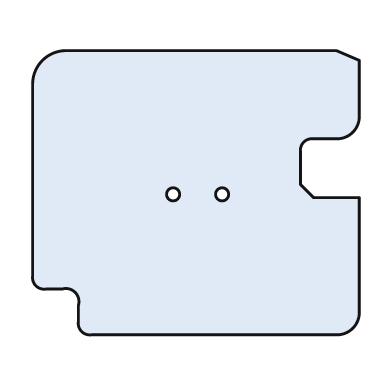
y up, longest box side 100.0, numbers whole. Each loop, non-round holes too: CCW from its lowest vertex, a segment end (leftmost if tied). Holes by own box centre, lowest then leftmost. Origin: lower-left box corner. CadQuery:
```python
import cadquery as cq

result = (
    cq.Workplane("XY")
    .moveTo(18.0, 0.0)
    .lineTo(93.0, 0.0)
    .threePointArc((98.0, 2.0), (100.0, 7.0))
    .lineTo(100.0, 42.0)
    .lineTo(86.0, 42.0)
    .lineTo(82.0, 46.0)
    .lineTo(82.0, 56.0)
    .threePointArc((83.0, 59.0), (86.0, 60.0))
    .lineTo(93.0, 60.0)
    .threePointArc((98.0, 62.0), (100.0, 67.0))
    .lineTo(100.0, 84.0)
    .lineTo(93.0, 87.0)
    .lineTo(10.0, 87.0)
    .threePointArc((3.0, 84.0), (0.0, 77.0))
    .lineTo(0.0, 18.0)
    .threePointArc((1.0, 15.0), (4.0, 14.0))
    .lineTo(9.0, 14.0)
    .threePointArc((13.0, 13.0), (14.0, 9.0))
    .lineTo(14.0, 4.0)
    .threePointArc((15.0, 1.0), (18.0, 0.0))
    .close()
    .moveTo(43.0, 43.0)
    .circle(2.0)
    .moveTo(58.0, 43.0)
    .circle(2.0)
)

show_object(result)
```